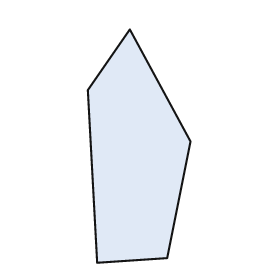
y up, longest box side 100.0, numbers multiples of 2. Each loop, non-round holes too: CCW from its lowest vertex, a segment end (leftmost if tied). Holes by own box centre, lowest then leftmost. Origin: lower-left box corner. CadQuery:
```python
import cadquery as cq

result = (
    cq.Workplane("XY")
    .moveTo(4.0, 0.0)
    .lineTo(34.0, 2.0)
    .lineTo(44.0, 52.0)
    .lineTo(18.0, 100.0)
    .lineTo(0.0, 74.0)
    .close()
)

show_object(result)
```